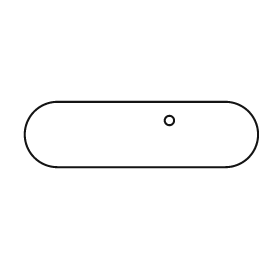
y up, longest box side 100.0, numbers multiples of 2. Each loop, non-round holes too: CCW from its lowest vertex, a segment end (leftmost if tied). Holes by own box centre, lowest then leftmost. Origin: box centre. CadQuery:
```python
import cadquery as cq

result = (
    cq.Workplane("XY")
    .moveTo(-36.0, -14.0)
    .lineTo(36.0, -14.0)
    .threePointArc((50.0, 0.0), (36.0, 14.0))
    .lineTo(-36.0, 14.0)
    .threePointArc((-50.0, 0.0), (-36.0, -14.0))
    .close()
    .moveTo(12.0, 6.0)
    .circle(2.0)
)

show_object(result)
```